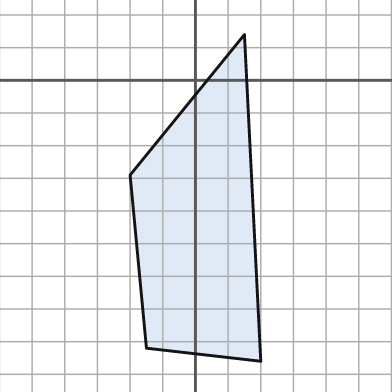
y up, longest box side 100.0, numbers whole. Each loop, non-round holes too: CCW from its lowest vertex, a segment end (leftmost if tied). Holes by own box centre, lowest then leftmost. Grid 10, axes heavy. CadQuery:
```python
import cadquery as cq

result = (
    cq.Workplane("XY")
    .moveTo(20.0, -86.0)
    .lineTo(15.0, 14.0)
    .lineTo(-20.0, -29.0)
    .lineTo(-15.0, -82.0)
    .close()
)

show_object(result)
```